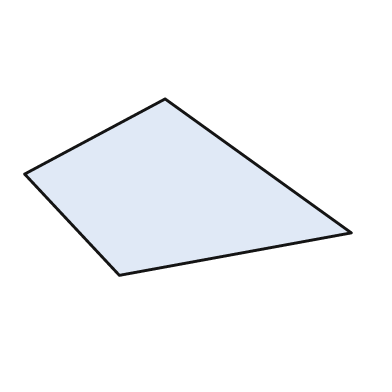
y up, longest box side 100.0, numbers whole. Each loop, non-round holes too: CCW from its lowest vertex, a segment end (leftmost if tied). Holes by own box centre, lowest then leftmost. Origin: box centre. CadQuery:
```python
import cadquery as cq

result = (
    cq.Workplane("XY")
    .moveTo(-21.0, -27.0)
    .lineTo(50.0, -14.0)
    .lineTo(-7.0, 27.0)
    .lineTo(-50.0, 4.0)
    .close()
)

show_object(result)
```